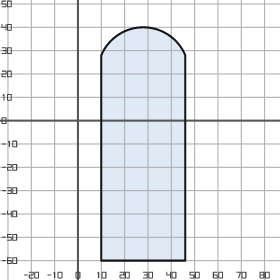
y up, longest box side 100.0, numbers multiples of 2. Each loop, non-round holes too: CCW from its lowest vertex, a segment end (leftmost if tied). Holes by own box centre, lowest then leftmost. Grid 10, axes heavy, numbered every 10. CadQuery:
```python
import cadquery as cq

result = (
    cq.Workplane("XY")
    .moveTo(10.0, -60.0)
    .lineTo(46.0, -60.0)
    .lineTo(46.0, 28.0)
    .threePointArc((28.0, 40.0), (10.0, 28.0))
    .close()
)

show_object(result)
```